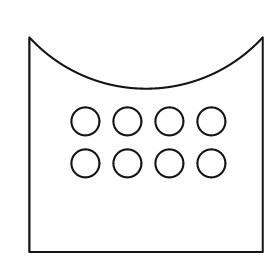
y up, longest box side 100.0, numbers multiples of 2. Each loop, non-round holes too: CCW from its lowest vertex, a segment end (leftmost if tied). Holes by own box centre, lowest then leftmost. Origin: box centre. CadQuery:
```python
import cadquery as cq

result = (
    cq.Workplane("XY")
    .moveTo(-50.0, -46.0)
    .lineTo(50.0, -46.0)
    .lineTo(50.0, 46.0)
    .threePointArc((0.0, 24.0), (-50.0, 46.0))
    .close()
    .moveTo(-26.0, -8.0)
    .circle(6.0)
    .moveTo(-8.0, -8.0)
    .circle(6.0)
    .moveTo(10.0, -8.0)
    .circle(6.0)
    .moveTo(28.0, -8.0)
    .circle(6.0)
    .moveTo(-26.0, 10.0)
    .circle(6.0)
    .moveTo(-8.0, 10.0)
    .circle(6.0)
    .moveTo(10.0, 10.0)
    .circle(6.0)
    .moveTo(28.0, 10.0)
    .circle(6.0)
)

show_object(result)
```